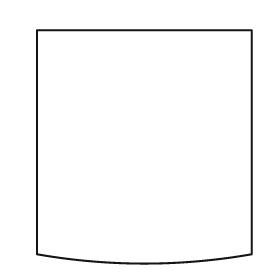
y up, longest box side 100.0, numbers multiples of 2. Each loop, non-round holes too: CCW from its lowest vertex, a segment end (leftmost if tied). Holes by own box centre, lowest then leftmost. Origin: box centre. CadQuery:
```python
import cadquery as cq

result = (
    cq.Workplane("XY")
    .moveTo(-46.0, -46.0)
    .threePointArc((0.0, -50.0), (46.0, -46.0))
    .lineTo(46.0, 50.0)
    .lineTo(-46.0, 50.0)
    .close()
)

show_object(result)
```